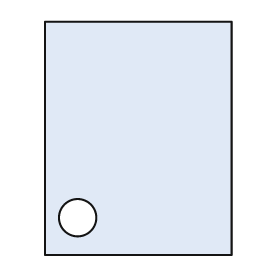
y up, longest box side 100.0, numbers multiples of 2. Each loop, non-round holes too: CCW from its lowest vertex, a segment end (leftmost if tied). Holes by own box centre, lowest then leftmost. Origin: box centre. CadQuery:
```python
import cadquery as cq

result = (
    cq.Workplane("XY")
    .moveTo(-40.0, -50.0)
    .lineTo(40.0, -50.0)
    .lineTo(40.0, 50.0)
    .lineTo(-40.0, 50.0)
    .close()
    .moveTo(-26.0, -34.0)
    .circle(8.0)
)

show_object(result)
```